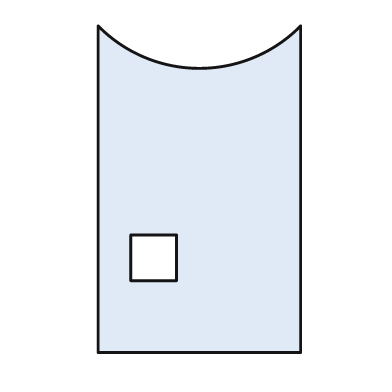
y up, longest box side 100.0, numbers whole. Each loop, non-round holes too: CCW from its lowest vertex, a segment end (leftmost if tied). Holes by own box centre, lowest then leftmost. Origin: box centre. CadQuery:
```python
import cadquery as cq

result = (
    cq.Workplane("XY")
    .moveTo(-31.0, -50.0)
    .lineTo(31.0, -50.0)
    .lineTo(31.0, 50.0)
    .threePointArc((0.0, 37.0), (-31.0, 50.0))
    .close()
    .moveTo(-21.0, -28.0)
    .lineTo(-7.0, -28.0)
    .lineTo(-7.0, -14.0)
    .lineTo(-21.0, -14.0)
    .close()
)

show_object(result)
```